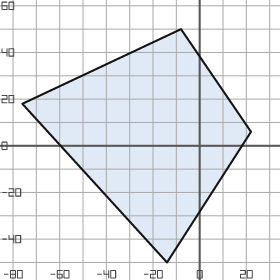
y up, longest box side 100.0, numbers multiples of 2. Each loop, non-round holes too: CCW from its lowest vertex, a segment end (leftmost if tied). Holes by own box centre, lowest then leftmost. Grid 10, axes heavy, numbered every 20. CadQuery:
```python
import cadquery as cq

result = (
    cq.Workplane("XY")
    .moveTo(-14.0, -50.0)
    .lineTo(22.0, 6.0)
    .lineTo(-8.0, 50.0)
    .lineTo(-76.0, 18.0)
    .close()
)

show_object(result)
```